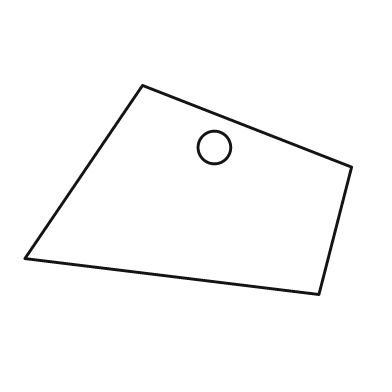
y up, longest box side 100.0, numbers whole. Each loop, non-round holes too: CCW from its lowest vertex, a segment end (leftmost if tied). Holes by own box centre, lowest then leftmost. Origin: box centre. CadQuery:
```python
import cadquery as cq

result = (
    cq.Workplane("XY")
    .moveTo(40.0, -32.0)
    .lineTo(50.0, 7.0)
    .lineTo(-14.0, 32.0)
    .lineTo(-50.0, -21.0)
    .close()
    .moveTo(8.0, 13.0)
    .circle(5.0)
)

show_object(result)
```